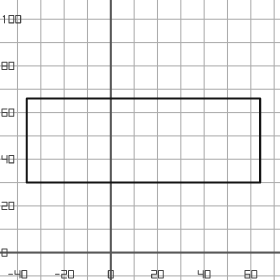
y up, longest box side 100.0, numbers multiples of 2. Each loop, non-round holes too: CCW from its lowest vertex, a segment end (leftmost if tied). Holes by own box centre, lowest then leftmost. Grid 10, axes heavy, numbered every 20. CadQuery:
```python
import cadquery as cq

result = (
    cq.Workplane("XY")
    .moveTo(-36.0, 30.0)
    .lineTo(64.0, 30.0)
    .lineTo(64.0, 66.0)
    .lineTo(-36.0, 66.0)
    .close()
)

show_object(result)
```